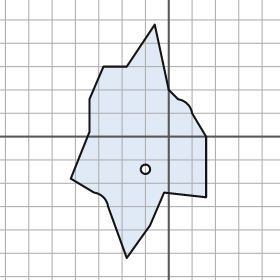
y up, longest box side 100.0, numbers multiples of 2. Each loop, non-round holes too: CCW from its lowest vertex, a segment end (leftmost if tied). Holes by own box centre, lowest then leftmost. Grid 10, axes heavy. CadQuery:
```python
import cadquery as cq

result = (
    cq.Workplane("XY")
    .moveTo(-18.0, -52.0)
    .lineTo(-8.0, -38.0)
    .lineTo(-2.0, -24.0)
    .lineTo(16.0, -26.0)
    .lineTo(16.0, 0.0)
    .lineTo(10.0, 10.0)
    .threePointArc((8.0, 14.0), (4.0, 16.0))
    .lineTo(0.0, 20.0)
    .lineTo(-6.0, 48.0)
    .lineTo(-18.0, 30.0)
    .lineTo(-28.0, 30.0)
    .lineTo(-34.0, 16.0)
    .lineTo(-34.0, 2.0)
    .lineTo(-42.0, -18.0)
    .lineTo(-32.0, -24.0)
    .threePointArc((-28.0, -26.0), (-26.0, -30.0))
    .close()
    .moveTo(-10.0, -14.0)
    .circle(2.0)
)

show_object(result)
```